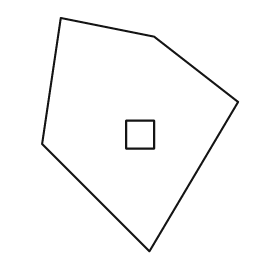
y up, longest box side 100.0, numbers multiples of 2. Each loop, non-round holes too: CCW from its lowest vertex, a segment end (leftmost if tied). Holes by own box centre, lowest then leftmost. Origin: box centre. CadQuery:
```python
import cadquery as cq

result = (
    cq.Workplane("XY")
    .moveTo(4.0, -50.0)
    .lineTo(42.0, 14.0)
    .lineTo(6.0, 42.0)
    .lineTo(-34.0, 50.0)
    .lineTo(-42.0, -4.0)
    .close()
    .moveTo(-6.0, -6.0)
    .lineTo(6.0, -6.0)
    .lineTo(6.0, 6.0)
    .lineTo(-6.0, 6.0)
    .close()
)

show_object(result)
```